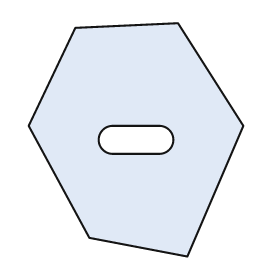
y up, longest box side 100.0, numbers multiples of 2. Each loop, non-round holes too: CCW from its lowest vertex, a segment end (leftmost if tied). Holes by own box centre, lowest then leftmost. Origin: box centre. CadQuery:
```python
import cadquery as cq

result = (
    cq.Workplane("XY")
    .moveTo(22.0, -50.0)
    .lineTo(46.0, 6.0)
    .lineTo(18.0, 50.0)
    .lineTo(-26.0, 48.0)
    .lineTo(-46.0, 6.0)
    .lineTo(-20.0, -42.0)
    .close()
    .moveTo(-10.0, -6.0)
    .lineTo(10.0, -6.0)
    .threePointArc((16.0, 0.0), (10.0, 6.0))
    .lineTo(-10.0, 6.0)
    .threePointArc((-16.0, 0.0), (-10.0, -6.0))
    .close()
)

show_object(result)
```